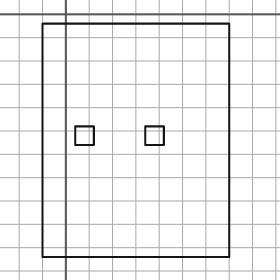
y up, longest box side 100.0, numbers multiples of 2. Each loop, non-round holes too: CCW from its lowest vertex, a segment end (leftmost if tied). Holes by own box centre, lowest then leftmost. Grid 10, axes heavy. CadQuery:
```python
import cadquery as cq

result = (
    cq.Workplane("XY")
    .moveTo(-10.0, -104.0)
    .lineTo(70.0, -104.0)
    .lineTo(70.0, -4.0)
    .lineTo(-10.0, -4.0)
    .close()
    .moveTo(4.0, -56.0)
    .lineTo(12.0, -56.0)
    .lineTo(12.0, -48.0)
    .lineTo(4.0, -48.0)
    .close()
    .moveTo(34.0, -56.0)
    .lineTo(42.0, -56.0)
    .lineTo(42.0, -48.0)
    .lineTo(34.0, -48.0)
    .close()
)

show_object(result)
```